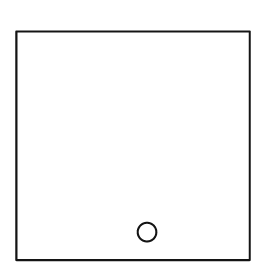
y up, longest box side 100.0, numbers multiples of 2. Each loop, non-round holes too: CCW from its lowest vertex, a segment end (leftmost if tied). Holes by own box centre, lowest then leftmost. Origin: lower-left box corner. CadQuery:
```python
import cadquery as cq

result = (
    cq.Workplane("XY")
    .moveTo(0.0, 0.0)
    .lineTo(100.0, 0.0)
    .lineTo(100.0, 98.0)
    .lineTo(0.0, 98.0)
    .close()
    .moveTo(56.0, 12.0)
    .circle(4.0)
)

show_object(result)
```